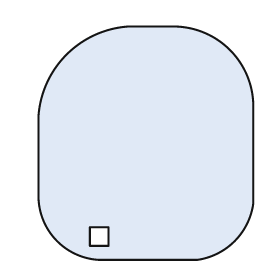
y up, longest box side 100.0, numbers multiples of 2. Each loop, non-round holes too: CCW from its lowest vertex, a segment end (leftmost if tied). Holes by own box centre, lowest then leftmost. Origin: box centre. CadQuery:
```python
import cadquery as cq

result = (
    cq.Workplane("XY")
    .moveTo(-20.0, -50.0)
    .lineTo(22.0, -50.0)
    .threePointArc((38.0, -42.0), (46.0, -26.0))
    .lineTo(46.0, 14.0)
    .threePointArc((36.0, 40.0), (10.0, 50.0))
    .lineTo(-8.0, 50.0)
    .threePointArc((-34.0, 38.0), (-46.0, 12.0))
    .lineTo(-46.0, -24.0)
    .threePointArc((-38.0, -42.0), (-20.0, -50.0))
    .close()
    .moveTo(-24.0, -44.0)
    .lineTo(-16.0, -44.0)
    .lineTo(-16.0, -36.0)
    .lineTo(-24.0, -36.0)
    .close()
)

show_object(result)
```